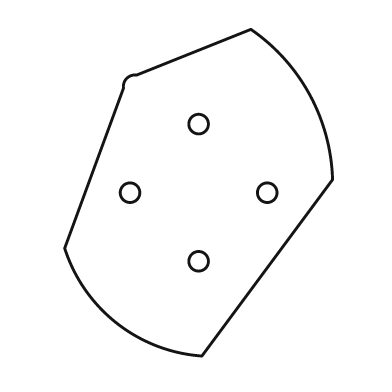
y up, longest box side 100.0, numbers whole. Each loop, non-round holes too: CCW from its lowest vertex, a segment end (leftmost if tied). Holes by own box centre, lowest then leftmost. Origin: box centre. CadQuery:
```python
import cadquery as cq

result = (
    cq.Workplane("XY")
    .moveTo(1.0, -50.0)
    .lineTo(41.0, 4.0)
    .threePointArc((34.0, 30.0), (16.0, 50.0))
    .lineTo(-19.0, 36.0)
    .threePointArc((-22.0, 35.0), (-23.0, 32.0))
    .lineTo(-41.0, -17.0)
    .threePointArc((-25.0, -40.0), (1.0, -50.0))
    .close()
    .moveTo(0.0, -21.0)
    .circle(3.0)
    .moveTo(-21.0, 0.0)
    .circle(3.0)
    .moveTo(21.0, 0.0)
    .circle(3.0)
    .moveTo(0.0, 21.0)
    .circle(3.0)
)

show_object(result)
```